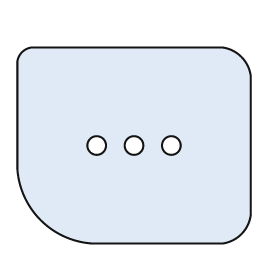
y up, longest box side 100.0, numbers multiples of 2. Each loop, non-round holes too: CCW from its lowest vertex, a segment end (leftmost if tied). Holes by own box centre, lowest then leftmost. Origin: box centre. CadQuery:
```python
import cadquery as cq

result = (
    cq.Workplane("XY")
    .moveTo(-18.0, -42.0)
    .lineTo(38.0, -42.0)
    .threePointArc((46.0, -38.0), (50.0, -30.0))
    .lineTo(50.0, 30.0)
    .threePointArc((46.0, 38.0), (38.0, 42.0))
    .lineTo(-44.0, 42.0)
    .threePointArc((-48.0, 40.0), (-50.0, 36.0))
    .lineTo(-50.0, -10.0)
    .threePointArc((-40.0, -32.0), (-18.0, -42.0))
    .close()
    .moveTo(-16.0, 0.0)
    .circle(4.0)
    .moveTo(0.0, 0.0)
    .circle(4.0)
    .moveTo(16.0, 0.0)
    .circle(4.0)
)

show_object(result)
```